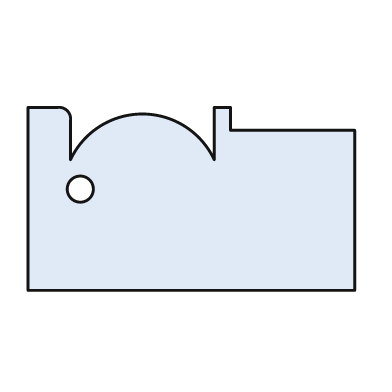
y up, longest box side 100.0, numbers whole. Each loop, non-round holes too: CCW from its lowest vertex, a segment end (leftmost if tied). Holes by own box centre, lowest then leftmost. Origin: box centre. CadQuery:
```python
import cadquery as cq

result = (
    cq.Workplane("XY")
    .moveTo(-50.0, -28.0)
    .lineTo(50.0, -28.0)
    .lineTo(50.0, 21.0)
    .lineTo(12.0, 21.0)
    .lineTo(12.0, 28.0)
    .lineTo(7.0, 28.0)
    .lineTo(7.0, 12.0)
    .threePointArc((-15.0, 26.0), (-37.0, 12.0))
    .lineTo(-37.0, 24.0)
    .threePointArc((-38.0, 27.0), (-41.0, 28.0))
    .lineTo(-50.0, 28.0)
    .close()
    .moveTo(-34.0, 3.0)
    .circle(4.0)
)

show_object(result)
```